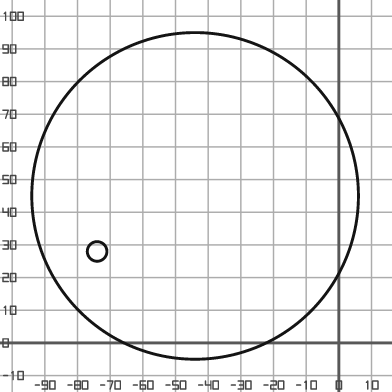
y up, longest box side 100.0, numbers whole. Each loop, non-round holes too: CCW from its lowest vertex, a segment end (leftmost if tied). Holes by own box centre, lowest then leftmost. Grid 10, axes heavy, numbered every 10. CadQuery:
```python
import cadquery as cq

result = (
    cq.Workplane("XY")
    .moveTo(-44.0, 45.0)
    .circle(50.0)
    .moveTo(-74.0, 28.0)
    .circle(3.0)
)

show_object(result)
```